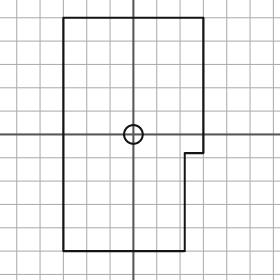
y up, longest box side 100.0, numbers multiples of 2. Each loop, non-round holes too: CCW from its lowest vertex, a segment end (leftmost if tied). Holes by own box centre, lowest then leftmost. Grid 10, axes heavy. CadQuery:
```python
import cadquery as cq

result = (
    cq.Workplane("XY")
    .moveTo(-30.0, -50.0)
    .lineTo(22.0, -50.0)
    .lineTo(22.0, -8.0)
    .lineTo(30.0, -8.0)
    .lineTo(30.0, 50.0)
    .lineTo(-30.0, 50.0)
    .close()
    .moveTo(0.0, 0.0)
    .circle(4.0)
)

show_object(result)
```